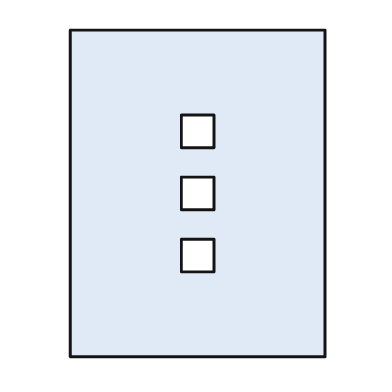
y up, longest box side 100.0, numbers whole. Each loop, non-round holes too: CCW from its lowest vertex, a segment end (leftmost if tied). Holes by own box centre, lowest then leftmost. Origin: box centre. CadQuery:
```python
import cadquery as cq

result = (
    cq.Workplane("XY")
    .moveTo(-39.0, -50.0)
    .lineTo(39.0, -50.0)
    .lineTo(39.0, 50.0)
    .lineTo(-39.0, 50.0)
    .close()
    .moveTo(-5.0, -24.0)
    .lineTo(5.0, -24.0)
    .lineTo(5.0, -14.0)
    .lineTo(-5.0, -14.0)
    .close()
    .moveTo(-5.0, -5.0)
    .lineTo(5.0, -5.0)
    .lineTo(5.0, 5.0)
    .lineTo(-5.0, 5.0)
    .close()
    .moveTo(-5.0, 14.0)
    .lineTo(5.0, 14.0)
    .lineTo(5.0, 24.0)
    .lineTo(-5.0, 24.0)
    .close()
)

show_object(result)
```